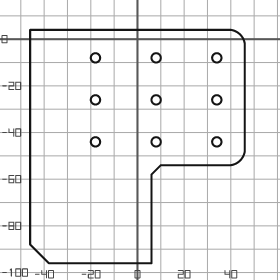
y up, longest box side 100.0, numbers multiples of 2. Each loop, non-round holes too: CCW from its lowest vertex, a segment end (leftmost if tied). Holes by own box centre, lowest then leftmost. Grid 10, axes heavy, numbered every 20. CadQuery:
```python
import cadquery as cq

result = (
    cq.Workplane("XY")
    .moveTo(-38.0, -96.0)
    .lineTo(6.0, -96.0)
    .lineTo(6.0, -58.0)
    .lineTo(10.0, -54.0)
    .lineTo(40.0, -54.0)
    .threePointArc((44.0, -52.0), (46.0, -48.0))
    .lineTo(46.0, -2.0)
    .threePointArc((44.0, 2.0), (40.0, 4.0))
    .lineTo(-46.0, 4.0)
    .lineTo(-46.0, -88.0)
    .close()
    .moveTo(-18.0, -44.0)
    .circle(2.0)
    .moveTo(8.0, -44.0)
    .circle(2.0)
    .moveTo(34.0, -44.0)
    .circle(2.0)
    .moveTo(-18.0, -26.0)
    .circle(2.0)
    .moveTo(8.0, -26.0)
    .circle(2.0)
    .moveTo(34.0, -26.0)
    .circle(2.0)
    .moveTo(-18.0, -8.0)
    .circle(2.0)
    .moveTo(8.0, -8.0)
    .circle(2.0)
    .moveTo(34.0, -8.0)
    .circle(2.0)
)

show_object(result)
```